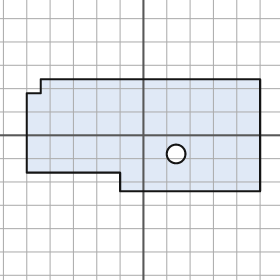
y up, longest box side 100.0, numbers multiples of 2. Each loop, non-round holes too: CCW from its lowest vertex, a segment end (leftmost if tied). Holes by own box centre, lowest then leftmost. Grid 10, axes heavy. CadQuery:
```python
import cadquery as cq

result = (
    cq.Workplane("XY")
    .moveTo(-10.0, -24.0)
    .lineTo(50.0, -24.0)
    .lineTo(50.0, 24.0)
    .lineTo(-44.0, 24.0)
    .lineTo(-44.0, 18.0)
    .lineTo(-50.0, 18.0)
    .lineTo(-50.0, -16.0)
    .lineTo(-10.0, -16.0)
    .close()
    .moveTo(14.0, -8.0)
    .circle(4.0)
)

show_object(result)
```